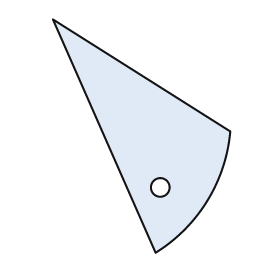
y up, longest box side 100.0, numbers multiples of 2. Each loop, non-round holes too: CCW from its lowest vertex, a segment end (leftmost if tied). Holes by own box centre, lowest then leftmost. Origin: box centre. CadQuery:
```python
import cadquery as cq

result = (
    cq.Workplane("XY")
    .moveTo(6.0, -50.0)
    .threePointArc((28.0, -28.0), (38.0, 2.0))
    .lineTo(-38.0, 50.0)
    .close()
    .moveTo(8.0, -22.0)
    .circle(4.0)
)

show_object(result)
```